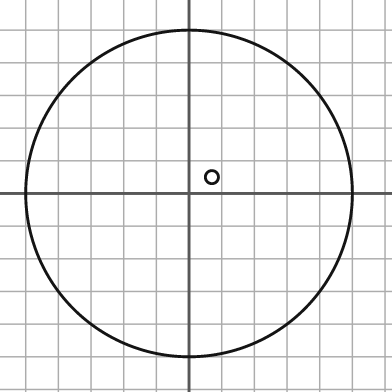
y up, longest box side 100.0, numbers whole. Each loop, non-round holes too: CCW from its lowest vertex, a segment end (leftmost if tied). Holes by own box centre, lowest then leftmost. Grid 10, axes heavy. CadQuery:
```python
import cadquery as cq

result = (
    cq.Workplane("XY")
    .moveTo(0.0, 0.0)
    .circle(50.0)
    .moveTo(7.0, 5.0)
    .circle(2.0)
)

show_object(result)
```